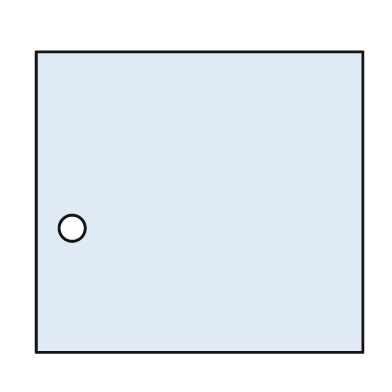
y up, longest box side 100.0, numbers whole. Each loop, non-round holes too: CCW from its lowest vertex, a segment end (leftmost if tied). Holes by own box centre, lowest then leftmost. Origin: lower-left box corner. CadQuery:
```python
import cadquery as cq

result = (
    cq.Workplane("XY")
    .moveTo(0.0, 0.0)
    .lineTo(100.0, 0.0)
    .lineTo(100.0, 92.0)
    .lineTo(0.0, 92.0)
    .close()
    .moveTo(11.0, 38.0)
    .circle(4.0)
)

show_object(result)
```